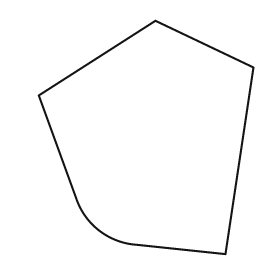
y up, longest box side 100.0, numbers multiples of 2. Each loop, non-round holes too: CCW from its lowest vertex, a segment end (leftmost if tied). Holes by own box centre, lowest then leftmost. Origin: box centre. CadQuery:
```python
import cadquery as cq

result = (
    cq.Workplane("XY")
    .moveTo(34.0, -50.0)
    .lineTo(46.0, 30.0)
    .lineTo(4.0, 50.0)
    .lineTo(-46.0, 18.0)
    .lineTo(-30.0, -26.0)
    .threePointArc((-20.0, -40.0), (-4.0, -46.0))
    .close()
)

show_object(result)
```